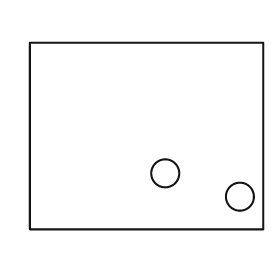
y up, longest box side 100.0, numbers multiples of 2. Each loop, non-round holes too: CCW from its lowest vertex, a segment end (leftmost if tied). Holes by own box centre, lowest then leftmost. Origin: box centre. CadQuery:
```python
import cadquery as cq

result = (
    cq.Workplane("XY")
    .moveTo(-50.0, -40.0)
    .lineTo(50.0, -40.0)
    .lineTo(50.0, 40.0)
    .lineTo(-50.0, 40.0)
    .close()
    .moveTo(40.0, -26.0)
    .circle(6.0)
    .moveTo(8.0, -16.0)
    .circle(6.0)
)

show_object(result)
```